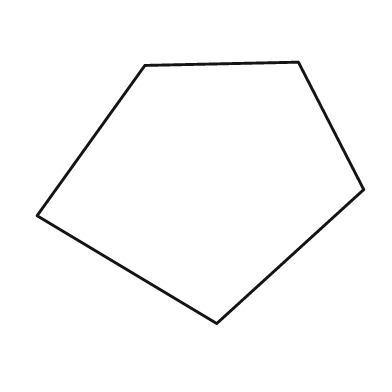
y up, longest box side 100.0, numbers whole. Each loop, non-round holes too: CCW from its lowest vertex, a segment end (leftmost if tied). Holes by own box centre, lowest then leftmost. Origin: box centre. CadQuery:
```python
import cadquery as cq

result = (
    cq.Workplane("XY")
    .moveTo(5.0, -40.0)
    .lineTo(50.0, 1.0)
    .lineTo(30.0, 40.0)
    .lineTo(-17.0, 39.0)
    .lineTo(-50.0, -7.0)
    .close()
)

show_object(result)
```